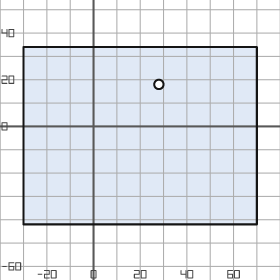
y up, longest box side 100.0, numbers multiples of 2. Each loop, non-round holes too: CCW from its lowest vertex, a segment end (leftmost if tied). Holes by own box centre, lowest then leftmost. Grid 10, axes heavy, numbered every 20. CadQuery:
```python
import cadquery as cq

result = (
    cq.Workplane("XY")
    .moveTo(-30.0, -42.0)
    .lineTo(70.0, -42.0)
    .lineTo(70.0, 34.0)
    .lineTo(-30.0, 34.0)
    .close()
    .moveTo(28.0, 18.0)
    .circle(2.0)
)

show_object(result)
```